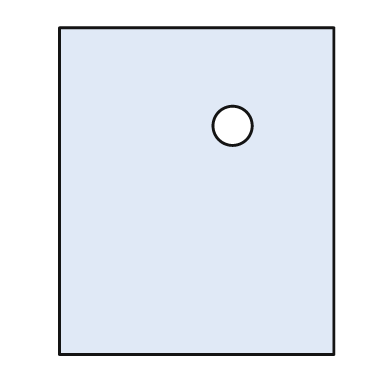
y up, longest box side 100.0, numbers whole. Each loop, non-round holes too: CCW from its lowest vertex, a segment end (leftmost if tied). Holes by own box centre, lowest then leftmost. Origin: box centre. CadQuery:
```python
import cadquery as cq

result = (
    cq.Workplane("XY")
    .moveTo(-42.0, -50.0)
    .lineTo(42.0, -50.0)
    .lineTo(42.0, 50.0)
    .lineTo(-42.0, 50.0)
    .close()
    .moveTo(11.0, 20.0)
    .circle(6.0)
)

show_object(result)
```